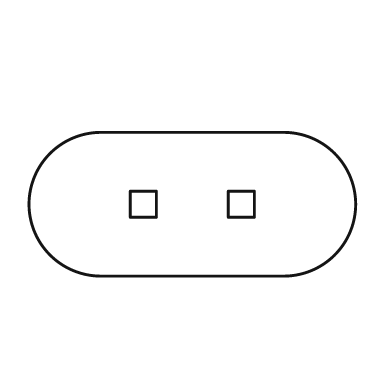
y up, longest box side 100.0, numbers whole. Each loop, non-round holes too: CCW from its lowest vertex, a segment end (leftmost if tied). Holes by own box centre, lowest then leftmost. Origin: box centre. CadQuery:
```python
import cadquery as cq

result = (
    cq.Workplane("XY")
    .moveTo(-28.0, -22.0)
    .lineTo(28.0, -22.0)
    .threePointArc((50.0, 0.0), (28.0, 22.0))
    .lineTo(-28.0, 22.0)
    .threePointArc((-50.0, 0.0), (-28.0, -22.0))
    .close()
    .moveTo(-19.0, -4.0)
    .lineTo(-11.0, -4.0)
    .lineTo(-11.0, 4.0)
    .lineTo(-19.0, 4.0)
    .close()
    .moveTo(11.0, -4.0)
    .lineTo(19.0, -4.0)
    .lineTo(19.0, 4.0)
    .lineTo(11.0, 4.0)
    .close()
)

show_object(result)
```